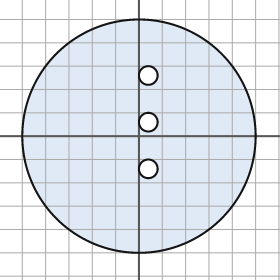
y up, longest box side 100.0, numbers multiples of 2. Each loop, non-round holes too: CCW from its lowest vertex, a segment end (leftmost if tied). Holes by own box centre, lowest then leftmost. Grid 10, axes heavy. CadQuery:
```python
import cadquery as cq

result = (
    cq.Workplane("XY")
    .moveTo(0.0, 0.0)
    .circle(50.0)
    .moveTo(4.0, -14.0)
    .circle(4.0)
    .moveTo(4.0, 6.0)
    .circle(4.0)
    .moveTo(4.0, 26.0)
    .circle(4.0)
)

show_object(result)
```